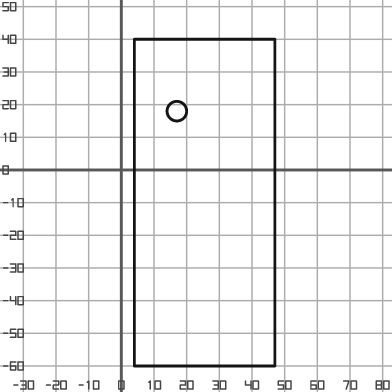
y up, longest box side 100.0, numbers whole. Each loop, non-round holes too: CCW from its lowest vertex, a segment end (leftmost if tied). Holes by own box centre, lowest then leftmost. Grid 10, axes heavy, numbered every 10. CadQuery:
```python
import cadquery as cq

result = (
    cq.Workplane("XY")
    .moveTo(4.0, -60.0)
    .lineTo(47.0, -60.0)
    .lineTo(47.0, 40.0)
    .lineTo(4.0, 40.0)
    .close()
    .moveTo(17.0, 18.0)
    .circle(3.0)
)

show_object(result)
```